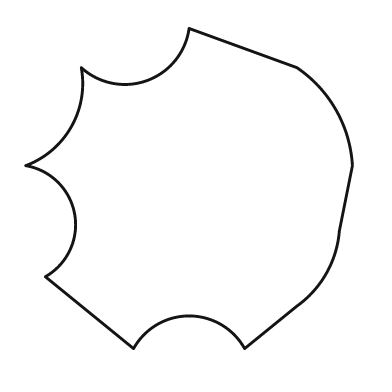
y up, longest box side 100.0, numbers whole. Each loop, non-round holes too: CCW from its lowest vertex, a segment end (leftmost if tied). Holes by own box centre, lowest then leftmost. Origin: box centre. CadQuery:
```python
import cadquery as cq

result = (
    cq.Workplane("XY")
    .moveTo(-17.0, -49.0)
    .threePointArc((0.0, -39.0), (17.0, -49.0))
    .lineTo(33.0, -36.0)
    .threePointArc((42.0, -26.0), (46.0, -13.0))
    .lineTo(50.0, 7.0)
    .threePointArc((45.0, 24.0), (33.0, 37.0))
    .lineTo(0.0, 49.0)
    .threePointArc((-13.0, 33.0), (-33.0, 37.0))
    .threePointArc((-36.0, 19.0), (-50.0, 7.0))
    .threePointArc((-35.0, -8.0), (-44.0, -27.0))
    .close()
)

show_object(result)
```